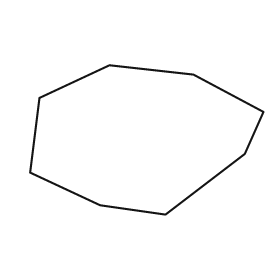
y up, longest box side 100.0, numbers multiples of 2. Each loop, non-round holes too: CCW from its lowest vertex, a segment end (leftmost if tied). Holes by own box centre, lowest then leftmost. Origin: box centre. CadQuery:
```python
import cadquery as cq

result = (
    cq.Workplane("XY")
    .moveTo(8.0, -32.0)
    .lineTo(42.0, -6.0)
    .lineTo(50.0, 12.0)
    .lineTo(20.0, 28.0)
    .lineTo(-16.0, 32.0)
    .lineTo(-46.0, 18.0)
    .lineTo(-50.0, -14.0)
    .lineTo(-20.0, -28.0)
    .close()
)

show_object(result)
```